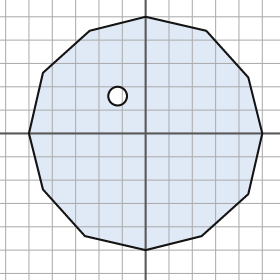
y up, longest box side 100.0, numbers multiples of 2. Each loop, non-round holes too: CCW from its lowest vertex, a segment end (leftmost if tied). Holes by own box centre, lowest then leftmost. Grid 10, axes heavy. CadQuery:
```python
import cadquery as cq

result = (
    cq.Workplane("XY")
    .moveTo(0.0, -50.0)
    .lineTo(24.0, -44.0)
    .lineTo(44.0, -26.0)
    .lineTo(50.0, 0.0)
    .lineTo(44.0, 24.0)
    .lineTo(26.0, 44.0)
    .lineTo(0.0, 50.0)
    .lineTo(-24.0, 44.0)
    .lineTo(-44.0, 26.0)
    .lineTo(-50.0, 0.0)
    .lineTo(-44.0, -24.0)
    .lineTo(-26.0, -44.0)
    .close()
    .moveTo(-12.0, 16.0)
    .circle(4.0)
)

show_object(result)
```